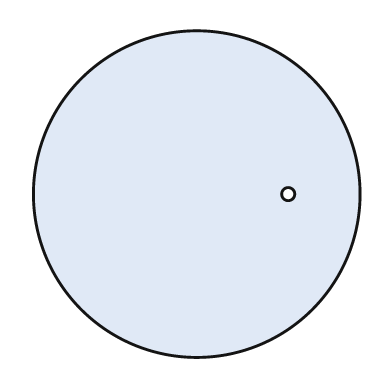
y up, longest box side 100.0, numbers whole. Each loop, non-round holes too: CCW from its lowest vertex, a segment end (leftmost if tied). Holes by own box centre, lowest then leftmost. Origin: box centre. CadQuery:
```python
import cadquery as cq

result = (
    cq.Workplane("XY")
    .moveTo(0.0, 0.0)
    .circle(50.0)
    .moveTo(28.0, 0.0)
    .circle(2.0)
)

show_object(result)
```